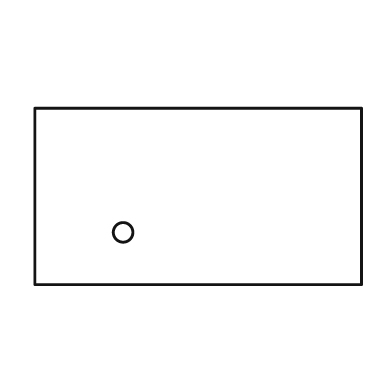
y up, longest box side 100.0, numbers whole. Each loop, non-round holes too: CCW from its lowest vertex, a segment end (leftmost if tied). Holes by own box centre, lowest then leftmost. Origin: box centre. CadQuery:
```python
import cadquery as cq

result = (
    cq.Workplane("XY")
    .moveTo(-50.0, -27.0)
    .lineTo(50.0, -27.0)
    .lineTo(50.0, 27.0)
    .lineTo(-50.0, 27.0)
    .close()
    .moveTo(-23.0, -11.0)
    .circle(3.0)
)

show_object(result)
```